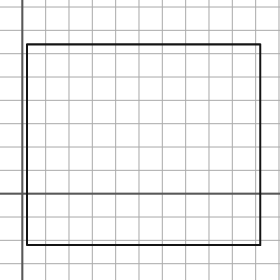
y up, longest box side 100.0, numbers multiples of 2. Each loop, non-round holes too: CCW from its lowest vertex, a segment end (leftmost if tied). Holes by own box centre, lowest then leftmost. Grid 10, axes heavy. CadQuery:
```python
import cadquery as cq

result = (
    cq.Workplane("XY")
    .moveTo(2.0, -22.0)
    .lineTo(102.0, -22.0)
    .lineTo(102.0, 64.0)
    .lineTo(2.0, 64.0)
    .close()
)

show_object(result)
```